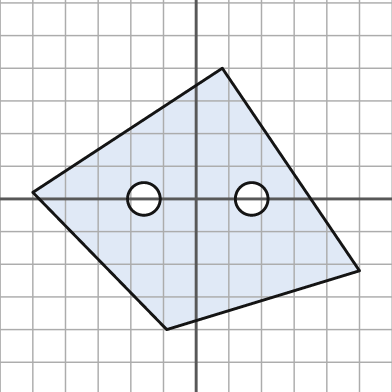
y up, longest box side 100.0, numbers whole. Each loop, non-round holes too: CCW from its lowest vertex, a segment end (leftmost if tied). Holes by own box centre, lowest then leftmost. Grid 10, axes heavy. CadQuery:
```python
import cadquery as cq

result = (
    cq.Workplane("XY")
    .moveTo(-9.0, -40.0)
    .lineTo(50.0, -22.0)
    .lineTo(8.0, 40.0)
    .lineTo(-50.0, 2.0)
    .close()
    .moveTo(-16.0, 0.0)
    .circle(5.0)
    .moveTo(17.0, 0.0)
    .circle(5.0)
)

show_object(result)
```